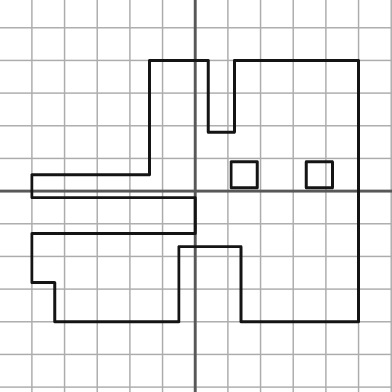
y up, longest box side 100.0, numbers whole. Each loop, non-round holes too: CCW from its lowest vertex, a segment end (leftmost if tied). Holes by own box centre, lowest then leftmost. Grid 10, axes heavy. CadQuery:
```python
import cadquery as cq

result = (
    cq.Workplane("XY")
    .moveTo(-43.0, -40.0)
    .lineTo(-5.0, -40.0)
    .lineTo(-5.0, -17.0)
    .lineTo(14.0, -17.0)
    .lineTo(14.0, -40.0)
    .lineTo(50.0, -40.0)
    .lineTo(50.0, 40.0)
    .lineTo(12.0, 40.0)
    .lineTo(12.0, 18.0)
    .lineTo(4.0, 18.0)
    .lineTo(4.0, 40.0)
    .lineTo(-14.0, 40.0)
    .lineTo(-14.0, 5.0)
    .lineTo(-50.0, 5.0)
    .lineTo(-50.0, -2.0)
    .lineTo(0.0, -2.0)
    .lineTo(0.0, -13.0)
    .lineTo(-50.0, -13.0)
    .lineTo(-50.0, -28.0)
    .lineTo(-43.0, -28.0)
    .close()
    .moveTo(11.0, 1.0)
    .lineTo(19.0, 1.0)
    .lineTo(19.0, 9.0)
    .lineTo(11.0, 9.0)
    .close()
    .moveTo(34.0, 1.0)
    .lineTo(42.0, 1.0)
    .lineTo(42.0, 9.0)
    .lineTo(34.0, 9.0)
    .close()
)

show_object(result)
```